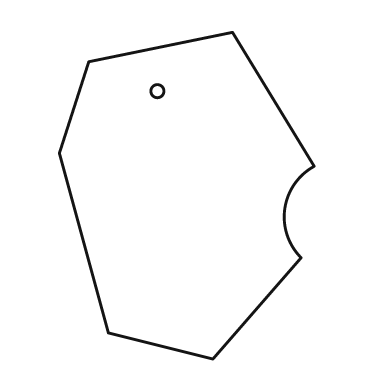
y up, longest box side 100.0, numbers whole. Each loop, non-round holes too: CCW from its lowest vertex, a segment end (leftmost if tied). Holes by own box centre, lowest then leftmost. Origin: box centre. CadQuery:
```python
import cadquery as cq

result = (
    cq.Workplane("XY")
    .moveTo(8.0, -50.0)
    .lineTo(35.0, -19.0)
    .threePointArc((30.0, -4.0), (39.0, 9.0))
    .lineTo(14.0, 50.0)
    .lineTo(-30.0, 41.0)
    .lineTo(-39.0, 13.0)
    .lineTo(-24.0, -42.0)
    .close()
    .moveTo(-9.0, 32.0)
    .circle(2.0)
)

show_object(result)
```